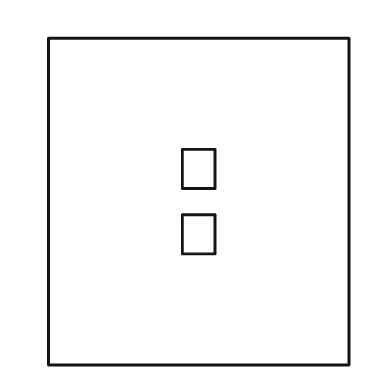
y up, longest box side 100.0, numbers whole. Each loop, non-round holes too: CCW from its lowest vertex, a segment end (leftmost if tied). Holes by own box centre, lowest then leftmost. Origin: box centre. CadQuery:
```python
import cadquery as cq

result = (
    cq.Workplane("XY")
    .moveTo(-46.0, -50.0)
    .lineTo(46.0, -50.0)
    .lineTo(46.0, 50.0)
    .lineTo(-46.0, 50.0)
    .close()
    .moveTo(-5.0, -16.0)
    .lineTo(5.0, -16.0)
    .lineTo(5.0, -4.0)
    .lineTo(-5.0, -4.0)
    .close()
    .moveTo(-5.0, 4.0)
    .lineTo(5.0, 4.0)
    .lineTo(5.0, 16.0)
    .lineTo(-5.0, 16.0)
    .close()
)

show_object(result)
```